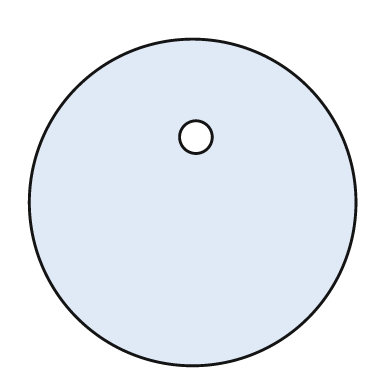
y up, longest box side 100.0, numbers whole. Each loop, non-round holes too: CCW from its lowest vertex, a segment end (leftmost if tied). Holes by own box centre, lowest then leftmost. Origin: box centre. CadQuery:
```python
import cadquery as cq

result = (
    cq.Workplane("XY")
    .moveTo(0.0, 0.0)
    .circle(50.0)
    .moveTo(1.0, 20.0)
    .circle(5.0)
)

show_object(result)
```